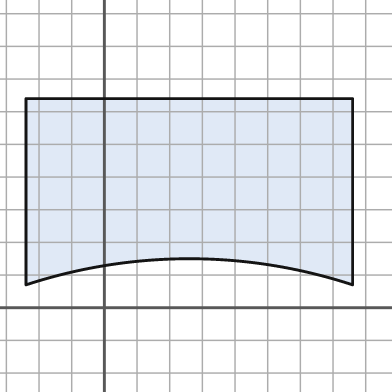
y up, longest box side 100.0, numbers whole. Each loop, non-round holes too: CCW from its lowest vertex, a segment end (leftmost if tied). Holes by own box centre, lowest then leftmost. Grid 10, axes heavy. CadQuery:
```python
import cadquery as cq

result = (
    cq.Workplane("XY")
    .moveTo(-24.0, 7.0)
    .threePointArc((26.0, 15.0), (76.0, 7.0))
    .lineTo(76.0, 64.0)
    .lineTo(-24.0, 64.0)
    .close()
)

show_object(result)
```